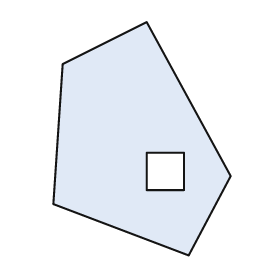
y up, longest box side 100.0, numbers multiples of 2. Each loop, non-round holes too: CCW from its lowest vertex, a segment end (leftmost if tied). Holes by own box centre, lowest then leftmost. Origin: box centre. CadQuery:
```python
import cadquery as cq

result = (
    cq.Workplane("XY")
    .moveTo(20.0, -50.0)
    .lineTo(38.0, -16.0)
    .lineTo(2.0, 50.0)
    .lineTo(-34.0, 32.0)
    .lineTo(-38.0, -28.0)
    .close()
    .moveTo(2.0, -22.0)
    .lineTo(18.0, -22.0)
    .lineTo(18.0, -6.0)
    .lineTo(2.0, -6.0)
    .close()
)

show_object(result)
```